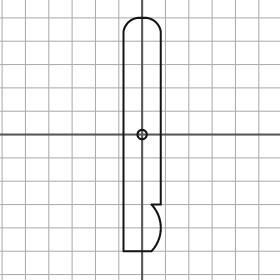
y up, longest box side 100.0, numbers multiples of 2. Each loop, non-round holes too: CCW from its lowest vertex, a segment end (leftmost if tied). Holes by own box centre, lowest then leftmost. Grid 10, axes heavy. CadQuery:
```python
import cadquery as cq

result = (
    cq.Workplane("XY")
    .moveTo(-8.0, -50.0)
    .lineTo(4.0, -50.0)
    .threePointArc((8.0, -40.0), (4.0, -30.0))
    .lineTo(8.0, -30.0)
    .lineTo(8.0, 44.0)
    .threePointArc((6.0, 48.0), (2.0, 50.0))
    .lineTo(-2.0, 50.0)
    .threePointArc((-6.0, 48.0), (-8.0, 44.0))
    .close()
    .moveTo(0.0, 0.0)
    .circle(2.0)
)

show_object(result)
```